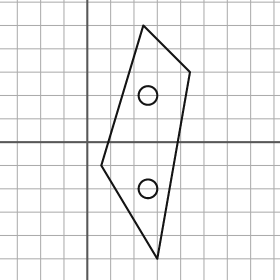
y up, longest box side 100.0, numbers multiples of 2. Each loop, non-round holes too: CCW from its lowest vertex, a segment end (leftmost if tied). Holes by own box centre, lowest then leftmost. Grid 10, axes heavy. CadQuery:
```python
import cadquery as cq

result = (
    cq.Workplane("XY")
    .moveTo(30.0, -50.0)
    .lineTo(44.0, 30.0)
    .lineTo(24.0, 50.0)
    .lineTo(6.0, -10.0)
    .close()
    .moveTo(26.0, -20.0)
    .circle(4.0)
    .moveTo(26.0, 20.0)
    .circle(4.0)
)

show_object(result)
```